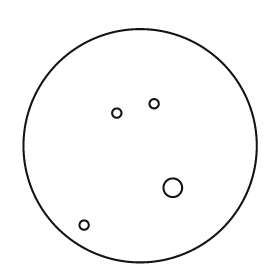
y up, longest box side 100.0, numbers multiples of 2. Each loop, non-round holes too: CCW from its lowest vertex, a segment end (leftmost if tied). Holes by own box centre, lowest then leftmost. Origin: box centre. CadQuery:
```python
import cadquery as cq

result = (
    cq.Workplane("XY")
    .moveTo(0.0, 0.0)
    .circle(50.0)
    .moveTo(-24.0, -34.0)
    .circle(2.0)
    .moveTo(14.0, -18.0)
    .circle(4.0)
    .moveTo(-10.0, 14.0)
    .circle(2.0)
    .moveTo(6.0, 18.0)
    .circle(2.0)
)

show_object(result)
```